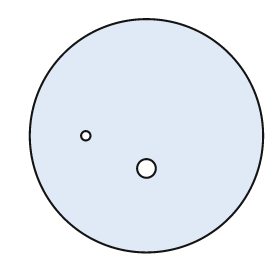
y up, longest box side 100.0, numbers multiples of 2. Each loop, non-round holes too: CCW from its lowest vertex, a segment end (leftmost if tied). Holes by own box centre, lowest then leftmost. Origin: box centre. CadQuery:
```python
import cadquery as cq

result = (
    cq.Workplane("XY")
    .moveTo(0.0, 0.0)
    .circle(50.0)
    .moveTo(0.0, -14.0)
    .circle(4.0)
    .moveTo(-26.0, 0.0)
    .circle(2.0)
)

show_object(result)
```